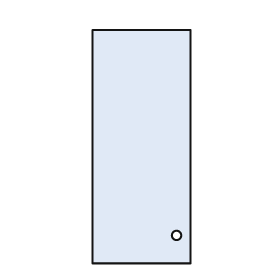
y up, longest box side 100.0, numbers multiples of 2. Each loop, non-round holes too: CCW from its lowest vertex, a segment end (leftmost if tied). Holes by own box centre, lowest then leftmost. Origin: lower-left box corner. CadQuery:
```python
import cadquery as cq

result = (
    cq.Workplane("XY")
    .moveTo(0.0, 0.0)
    .lineTo(42.0, 0.0)
    .lineTo(42.0, 100.0)
    .lineTo(0.0, 100.0)
    .close()
    .moveTo(36.0, 12.0)
    .circle(2.0)
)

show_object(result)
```